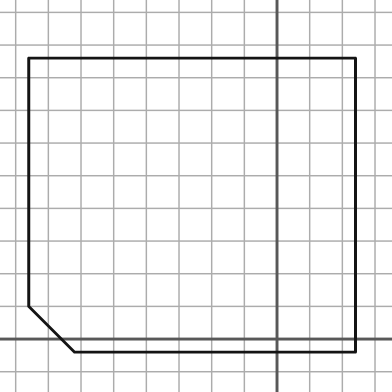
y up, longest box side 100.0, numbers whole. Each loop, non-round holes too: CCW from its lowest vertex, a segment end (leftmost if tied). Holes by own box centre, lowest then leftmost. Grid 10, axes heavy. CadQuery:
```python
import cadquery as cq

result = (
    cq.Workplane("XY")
    .moveTo(-62.0, -4.0)
    .lineTo(24.0, -4.0)
    .lineTo(24.0, 86.0)
    .lineTo(-76.0, 86.0)
    .lineTo(-76.0, 10.0)
    .close()
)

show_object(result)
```